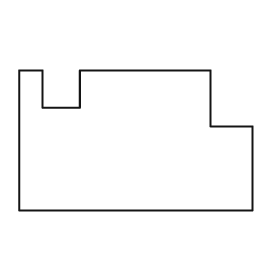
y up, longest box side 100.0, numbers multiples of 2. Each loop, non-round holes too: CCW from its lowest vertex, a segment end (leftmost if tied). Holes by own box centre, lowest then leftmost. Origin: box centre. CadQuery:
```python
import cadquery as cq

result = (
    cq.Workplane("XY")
    .moveTo(-50.0, -30.0)
    .lineTo(50.0, -30.0)
    .lineTo(50.0, 6.0)
    .lineTo(32.0, 6.0)
    .lineTo(32.0, 30.0)
    .lineTo(-24.0, 30.0)
    .lineTo(-24.0, 14.0)
    .lineTo(-40.0, 14.0)
    .lineTo(-40.0, 30.0)
    .lineTo(-50.0, 30.0)
    .close()
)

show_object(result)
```